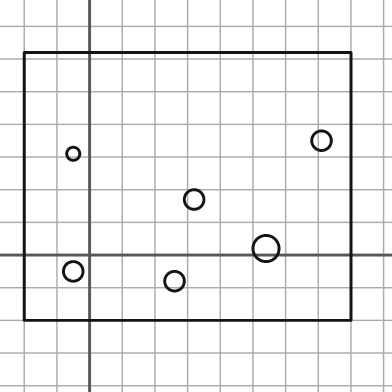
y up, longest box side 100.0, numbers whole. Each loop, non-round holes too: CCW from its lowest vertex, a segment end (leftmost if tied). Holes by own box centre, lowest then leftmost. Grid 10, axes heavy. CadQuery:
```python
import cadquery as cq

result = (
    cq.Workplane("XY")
    .moveTo(-20.0, -20.0)
    .lineTo(80.0, -20.0)
    .lineTo(80.0, 62.0)
    .lineTo(-20.0, 62.0)
    .close()
    .moveTo(26.0, -8.0)
    .circle(3.0)
    .moveTo(-5.0, -5.0)
    .circle(3.0)
    .moveTo(54.0, 2.0)
    .circle(4.0)
    .moveTo(32.0, 17.0)
    .circle(3.0)
    .moveTo(-5.0, 31.0)
    .circle(2.0)
    .moveTo(71.0, 35.0)
    .circle(3.0)
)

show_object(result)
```